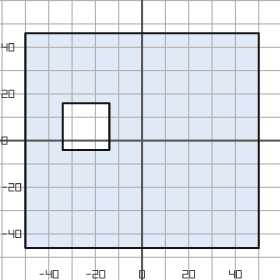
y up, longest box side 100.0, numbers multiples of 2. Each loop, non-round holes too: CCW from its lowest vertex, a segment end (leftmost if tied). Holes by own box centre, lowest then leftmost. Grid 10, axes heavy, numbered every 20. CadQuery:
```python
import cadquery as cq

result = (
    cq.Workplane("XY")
    .moveTo(-50.0, -46.0)
    .lineTo(50.0, -46.0)
    .lineTo(50.0, 46.0)
    .lineTo(-50.0, 46.0)
    .close()
    .moveTo(-34.0, -4.0)
    .lineTo(-14.0, -4.0)
    .lineTo(-14.0, 16.0)
    .lineTo(-34.0, 16.0)
    .close()
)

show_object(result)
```